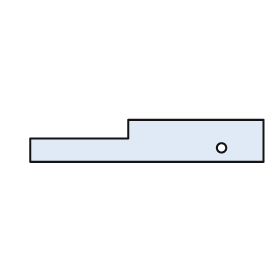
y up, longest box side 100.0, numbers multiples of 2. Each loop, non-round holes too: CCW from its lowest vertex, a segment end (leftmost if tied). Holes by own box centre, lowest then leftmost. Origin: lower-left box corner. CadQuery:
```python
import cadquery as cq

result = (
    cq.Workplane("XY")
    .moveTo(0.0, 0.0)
    .lineTo(100.0, 0.0)
    .lineTo(100.0, 18.0)
    .lineTo(42.0, 18.0)
    .lineTo(42.0, 10.0)
    .lineTo(0.0, 10.0)
    .close()
    .moveTo(82.0, 6.0)
    .circle(2.0)
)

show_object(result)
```